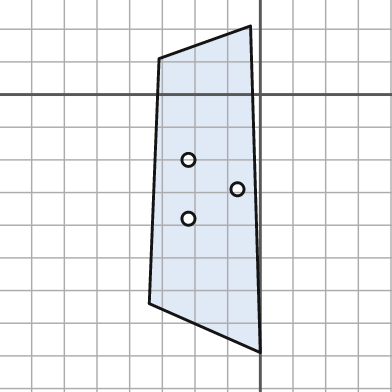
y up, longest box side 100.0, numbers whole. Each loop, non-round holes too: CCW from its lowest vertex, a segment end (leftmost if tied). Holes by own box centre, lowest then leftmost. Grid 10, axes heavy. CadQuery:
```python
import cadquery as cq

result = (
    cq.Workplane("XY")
    .moveTo(0.0, -79.0)
    .lineTo(-3.0, 21.0)
    .lineTo(-31.0, 11.0)
    .lineTo(-34.0, -64.0)
    .close()
    .moveTo(-22.0, -38.0)
    .circle(2.0)
    .moveTo(-7.0, -29.0)
    .circle(2.0)
    .moveTo(-22.0, -20.0)
    .circle(2.0)
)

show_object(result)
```